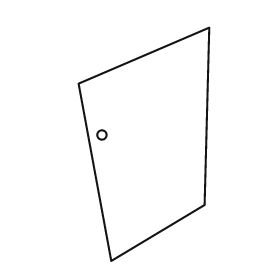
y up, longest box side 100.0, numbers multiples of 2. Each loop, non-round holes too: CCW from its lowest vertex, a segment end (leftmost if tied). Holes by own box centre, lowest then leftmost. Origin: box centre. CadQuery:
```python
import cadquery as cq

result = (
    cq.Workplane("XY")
    .moveTo(-14.0, -50.0)
    .lineTo(26.0, -26.0)
    .lineTo(28.0, 50.0)
    .lineTo(-28.0, 26.0)
    .close()
    .moveTo(-18.0, 4.0)
    .circle(2.0)
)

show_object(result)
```